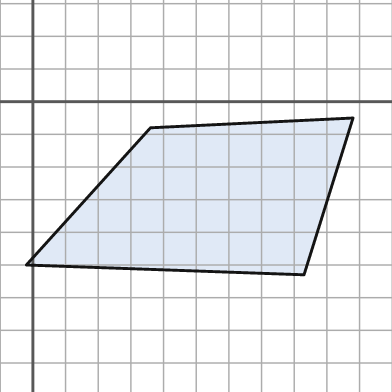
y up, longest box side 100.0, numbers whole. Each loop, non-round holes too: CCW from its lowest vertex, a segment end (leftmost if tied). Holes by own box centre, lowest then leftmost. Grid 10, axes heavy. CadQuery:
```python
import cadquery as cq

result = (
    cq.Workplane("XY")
    .moveTo(83.0, -53.0)
    .lineTo(98.0, -5.0)
    .lineTo(36.0, -8.0)
    .lineTo(-2.0, -50.0)
    .close()
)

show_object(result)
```